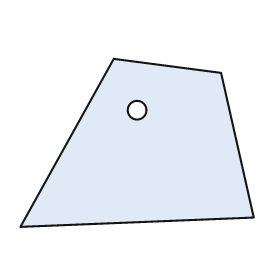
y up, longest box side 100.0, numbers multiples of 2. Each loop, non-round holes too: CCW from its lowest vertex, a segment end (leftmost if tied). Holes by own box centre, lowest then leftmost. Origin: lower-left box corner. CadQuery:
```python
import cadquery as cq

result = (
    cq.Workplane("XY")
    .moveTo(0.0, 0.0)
    .lineTo(100.0, 4.0)
    .lineTo(86.0, 66.0)
    .lineTo(40.0, 72.0)
    .close()
    .moveTo(50.0, 50.0)
    .circle(4.0)
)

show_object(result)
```